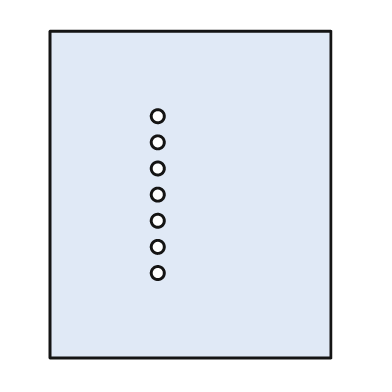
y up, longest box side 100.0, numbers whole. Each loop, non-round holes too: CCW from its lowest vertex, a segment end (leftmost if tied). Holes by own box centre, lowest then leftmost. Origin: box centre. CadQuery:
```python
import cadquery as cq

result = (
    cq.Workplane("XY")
    .moveTo(-43.0, -50.0)
    .lineTo(43.0, -50.0)
    .lineTo(43.0, 50.0)
    .lineTo(-43.0, 50.0)
    .close()
    .moveTo(-10.0, -24.0)
    .circle(2.0)
    .moveTo(-10.0, -16.0)
    .circle(2.0)
    .moveTo(-10.0, -8.0)
    .circle(2.0)
    .moveTo(-10.0, 0.0)
    .circle(2.0)
    .moveTo(-10.0, 8.0)
    .circle(2.0)
    .moveTo(-10.0, 16.0)
    .circle(2.0)
    .moveTo(-10.0, 24.0)
    .circle(2.0)
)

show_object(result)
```